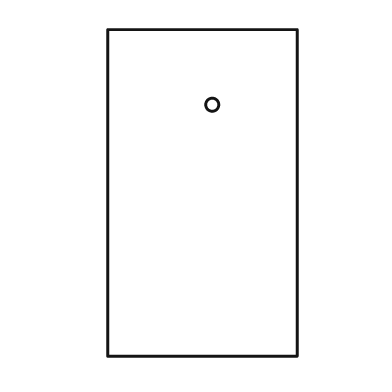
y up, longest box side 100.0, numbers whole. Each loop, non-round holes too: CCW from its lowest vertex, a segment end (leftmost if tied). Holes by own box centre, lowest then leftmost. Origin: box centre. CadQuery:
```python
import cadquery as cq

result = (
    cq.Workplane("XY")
    .moveTo(-29.0, -50.0)
    .lineTo(29.0, -50.0)
    .lineTo(29.0, 50.0)
    .lineTo(-29.0, 50.0)
    .close()
    .moveTo(3.0, 27.0)
    .circle(2.0)
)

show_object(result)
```